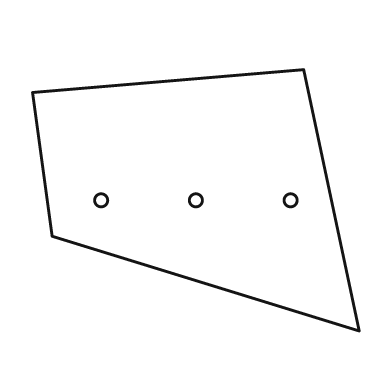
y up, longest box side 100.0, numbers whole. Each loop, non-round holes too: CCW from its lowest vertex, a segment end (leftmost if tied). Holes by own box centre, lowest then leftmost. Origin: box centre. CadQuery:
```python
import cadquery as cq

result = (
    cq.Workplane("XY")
    .moveTo(50.0, -40.0)
    .lineTo(33.0, 40.0)
    .lineTo(-50.0, 33.0)
    .lineTo(-44.0, -11.0)
    .close()
    .moveTo(-29.0, 0.0)
    .circle(2.0)
    .moveTo(0.0, 0.0)
    .circle(2.0)
    .moveTo(29.0, 0.0)
    .circle(2.0)
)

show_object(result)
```